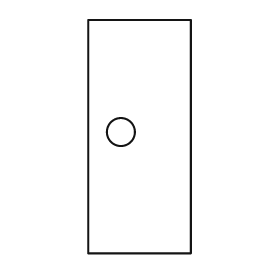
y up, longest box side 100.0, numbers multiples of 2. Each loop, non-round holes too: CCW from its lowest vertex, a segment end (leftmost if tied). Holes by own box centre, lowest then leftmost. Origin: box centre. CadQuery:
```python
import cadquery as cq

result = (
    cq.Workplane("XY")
    .moveTo(-22.0, -50.0)
    .lineTo(22.0, -50.0)
    .lineTo(22.0, 50.0)
    .lineTo(-22.0, 50.0)
    .close()
    .moveTo(-8.0, 2.0)
    .circle(6.0)
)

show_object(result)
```